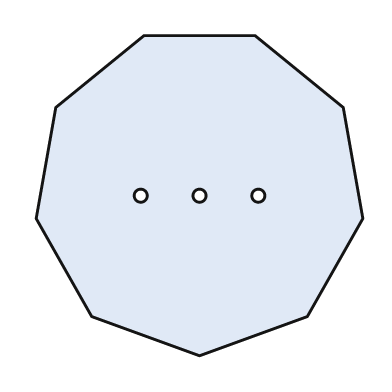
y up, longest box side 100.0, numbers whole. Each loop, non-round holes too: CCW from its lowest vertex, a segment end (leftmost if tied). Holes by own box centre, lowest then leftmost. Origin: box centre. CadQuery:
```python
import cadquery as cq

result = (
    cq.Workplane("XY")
    .moveTo(0.0, -49.0)
    .lineTo(33.0, -37.0)
    .lineTo(50.0, -7.0)
    .lineTo(44.0, 27.0)
    .lineTo(17.0, 49.0)
    .lineTo(-17.0, 49.0)
    .lineTo(-44.0, 27.0)
    .lineTo(-50.0, -7.0)
    .lineTo(-33.0, -37.0)
    .close()
    .moveTo(-18.0, 0.0)
    .circle(2.0)
    .moveTo(0.0, 0.0)
    .circle(2.0)
    .moveTo(18.0, 0.0)
    .circle(2.0)
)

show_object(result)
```